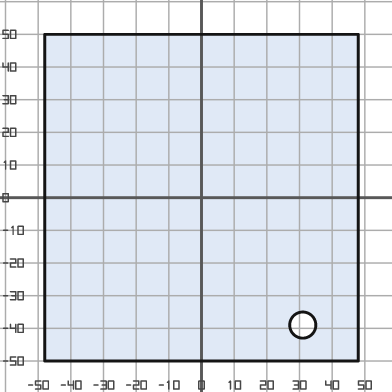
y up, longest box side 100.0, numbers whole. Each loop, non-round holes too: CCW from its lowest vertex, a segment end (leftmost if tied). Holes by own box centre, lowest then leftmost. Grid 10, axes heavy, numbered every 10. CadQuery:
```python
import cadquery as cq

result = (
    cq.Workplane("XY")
    .moveTo(-48.0, -50.0)
    .lineTo(48.0, -50.0)
    .lineTo(48.0, 50.0)
    .lineTo(-48.0, 50.0)
    .close()
    .moveTo(31.0, -39.0)
    .circle(4.0)
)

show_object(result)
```